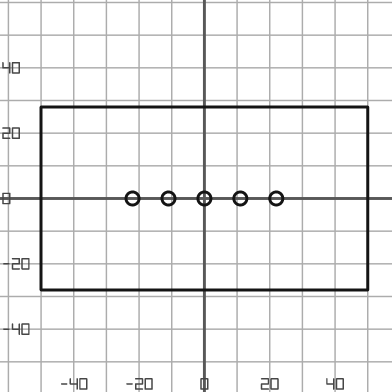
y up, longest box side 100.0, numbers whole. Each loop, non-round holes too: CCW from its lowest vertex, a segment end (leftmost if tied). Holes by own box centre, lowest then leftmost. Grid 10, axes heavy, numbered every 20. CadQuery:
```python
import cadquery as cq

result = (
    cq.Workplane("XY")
    .moveTo(-50.0, -28.0)
    .lineTo(50.0, -28.0)
    .lineTo(50.0, 28.0)
    .lineTo(-50.0, 28.0)
    .close()
    .moveTo(-22.0, 0.0)
    .circle(2.0)
    .moveTo(-11.0, 0.0)
    .circle(2.0)
    .moveTo(0.0, 0.0)
    .circle(2.0)
    .moveTo(11.0, 0.0)
    .circle(2.0)
    .moveTo(22.0, 0.0)
    .circle(2.0)
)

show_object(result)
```